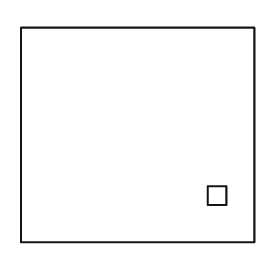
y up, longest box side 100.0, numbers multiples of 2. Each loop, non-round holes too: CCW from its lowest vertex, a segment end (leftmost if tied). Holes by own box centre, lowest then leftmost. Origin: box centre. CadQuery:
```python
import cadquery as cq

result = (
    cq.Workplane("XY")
    .moveTo(-50.0, -46.0)
    .lineTo(50.0, -46.0)
    .lineTo(50.0, 46.0)
    .lineTo(-50.0, 46.0)
    .close()
    .moveTo(30.0, -30.0)
    .lineTo(38.0, -30.0)
    .lineTo(38.0, -22.0)
    .lineTo(30.0, -22.0)
    .close()
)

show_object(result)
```